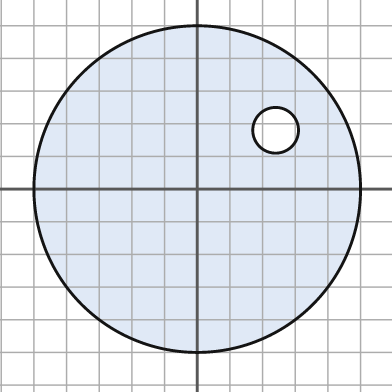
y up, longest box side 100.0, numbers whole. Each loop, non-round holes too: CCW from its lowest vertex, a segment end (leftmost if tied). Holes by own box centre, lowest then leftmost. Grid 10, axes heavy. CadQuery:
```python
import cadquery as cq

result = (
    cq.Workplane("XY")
    .moveTo(0.0, 0.0)
    .circle(50.0)
    .moveTo(24.0, 18.0)
    .circle(7.0)
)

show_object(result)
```